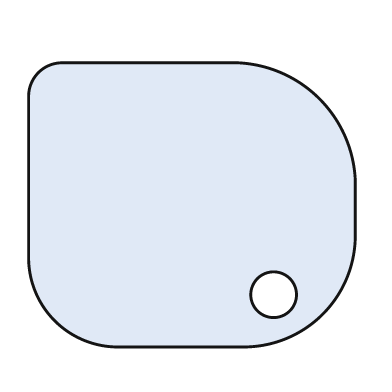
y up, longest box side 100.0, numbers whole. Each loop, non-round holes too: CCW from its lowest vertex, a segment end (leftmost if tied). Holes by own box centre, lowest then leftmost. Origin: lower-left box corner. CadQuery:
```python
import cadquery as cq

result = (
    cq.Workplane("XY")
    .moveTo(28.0, 0.0)
    .lineTo(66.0, 0.0)
    .threePointArc((90.0, 10.0), (100.0, 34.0))
    .lineTo(100.0, 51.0)
    .threePointArc((89.0, 76.0), (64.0, 87.0))
    .lineTo(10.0, 87.0)
    .threePointArc((3.0, 84.0), (0.0, 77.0))
    .lineTo(0.0, 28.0)
    .threePointArc((8.0, 8.0), (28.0, 0.0))
    .close()
    .moveTo(75.0, 16.0)
    .circle(7.0)
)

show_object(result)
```